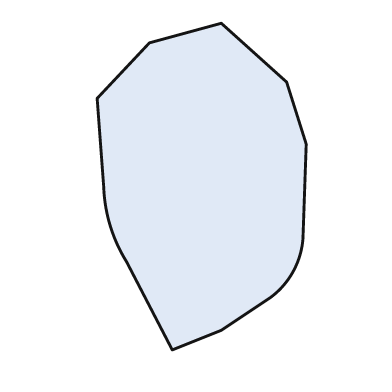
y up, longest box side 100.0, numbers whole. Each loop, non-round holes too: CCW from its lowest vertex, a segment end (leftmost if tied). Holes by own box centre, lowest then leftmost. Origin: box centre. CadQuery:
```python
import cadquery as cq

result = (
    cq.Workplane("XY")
    .moveTo(-9.0, -50.0)
    .lineTo(6.0, -44.0)
    .lineTo(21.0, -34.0)
    .threePointArc((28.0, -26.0), (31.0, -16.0))
    .lineTo(32.0, 13.0)
    .lineTo(26.0, 32.0)
    .lineTo(6.0, 50.0)
    .lineTo(-16.0, 44.0)
    .lineTo(-32.0, 27.0)
    .lineTo(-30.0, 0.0)
    .threePointArc((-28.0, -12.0), (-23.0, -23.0))
    .close()
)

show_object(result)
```